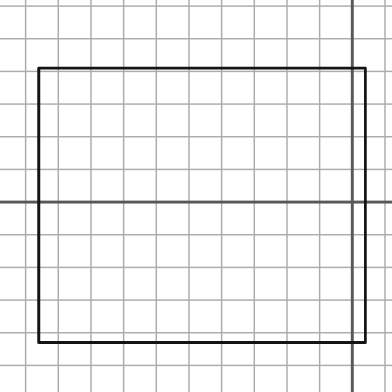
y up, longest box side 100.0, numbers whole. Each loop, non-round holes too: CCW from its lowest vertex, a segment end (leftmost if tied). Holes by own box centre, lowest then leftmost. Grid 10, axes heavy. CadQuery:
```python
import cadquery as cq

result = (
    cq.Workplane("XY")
    .moveTo(-96.0, -43.0)
    .lineTo(4.0, -43.0)
    .lineTo(4.0, 41.0)
    .lineTo(-96.0, 41.0)
    .close()
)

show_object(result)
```